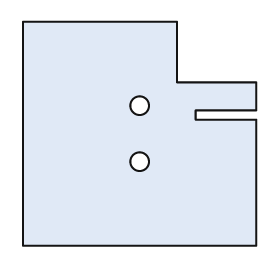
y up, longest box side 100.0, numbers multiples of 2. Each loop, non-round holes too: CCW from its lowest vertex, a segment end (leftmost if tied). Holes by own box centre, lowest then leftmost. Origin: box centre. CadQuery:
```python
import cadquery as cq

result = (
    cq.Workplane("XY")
    .moveTo(-50.0, -48.0)
    .lineTo(50.0, -48.0)
    .lineTo(50.0, 6.0)
    .lineTo(24.0, 6.0)
    .lineTo(24.0, 10.0)
    .lineTo(50.0, 10.0)
    .lineTo(50.0, 22.0)
    .lineTo(16.0, 22.0)
    .lineTo(16.0, 48.0)
    .lineTo(-50.0, 48.0)
    .close()
    .moveTo(0.0, -12.0)
    .circle(4.0)
    .moveTo(0.0, 12.0)
    .circle(4.0)
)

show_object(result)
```